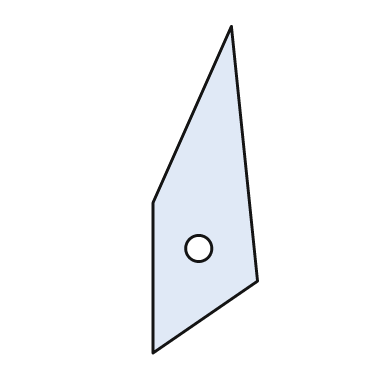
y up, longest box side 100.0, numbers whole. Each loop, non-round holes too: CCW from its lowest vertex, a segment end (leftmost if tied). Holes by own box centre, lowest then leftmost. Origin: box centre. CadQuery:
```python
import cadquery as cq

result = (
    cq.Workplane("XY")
    .moveTo(-16.0, -50.0)
    .lineTo(16.0, -28.0)
    .lineTo(8.0, 50.0)
    .lineTo(-16.0, -4.0)
    .close()
    .moveTo(-2.0, -18.0)
    .circle(4.0)
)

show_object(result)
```